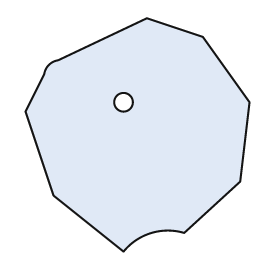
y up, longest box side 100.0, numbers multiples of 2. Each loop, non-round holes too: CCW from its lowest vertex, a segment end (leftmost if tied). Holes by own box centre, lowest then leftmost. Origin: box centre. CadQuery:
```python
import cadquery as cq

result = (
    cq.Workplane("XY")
    .moveTo(-6.0, -50.0)
    .threePointArc((6.0, -42.0), (20.0, -42.0))
    .lineTo(44.0, -20.0)
    .lineTo(48.0, 14.0)
    .lineTo(28.0, 42.0)
    .lineTo(4.0, 50.0)
    .lineTo(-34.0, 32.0)
    .threePointArc((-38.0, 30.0), (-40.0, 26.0))
    .lineTo(-48.0, 10.0)
    .lineTo(-36.0, -26.0)
    .close()
    .moveTo(-6.0, 14.0)
    .circle(4.0)
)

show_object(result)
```